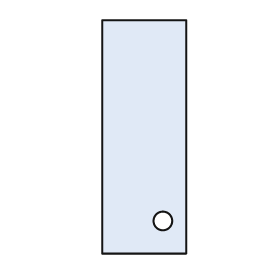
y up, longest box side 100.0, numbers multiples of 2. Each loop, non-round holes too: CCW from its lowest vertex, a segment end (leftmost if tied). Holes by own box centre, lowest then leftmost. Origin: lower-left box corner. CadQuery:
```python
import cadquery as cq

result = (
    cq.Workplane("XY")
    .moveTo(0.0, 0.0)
    .lineTo(36.0, 0.0)
    .lineTo(36.0, 100.0)
    .lineTo(0.0, 100.0)
    .close()
    .moveTo(26.0, 14.0)
    .circle(4.0)
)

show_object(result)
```